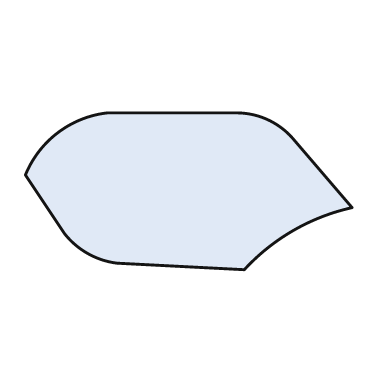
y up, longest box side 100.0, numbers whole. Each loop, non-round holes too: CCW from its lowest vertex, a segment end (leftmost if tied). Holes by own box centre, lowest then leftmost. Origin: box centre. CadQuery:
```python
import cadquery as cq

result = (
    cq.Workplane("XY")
    .moveTo(17.0, -24.0)
    .threePointArc((32.0, -12.0), (50.0, -5.0))
    .lineTo(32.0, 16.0)
    .threePointArc((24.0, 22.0), (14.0, 24.0))
    .lineTo(-25.0, 24.0)
    .threePointArc((-40.0, 18.0), (-50.0, 5.0))
    .lineTo(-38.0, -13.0)
    .threePointArc((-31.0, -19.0), (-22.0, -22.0))
    .close()
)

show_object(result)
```